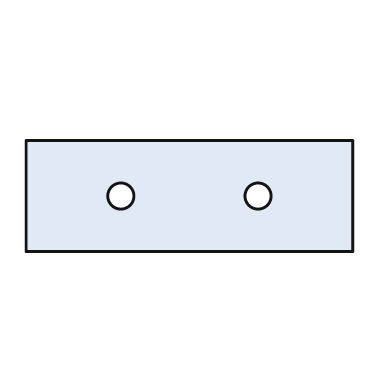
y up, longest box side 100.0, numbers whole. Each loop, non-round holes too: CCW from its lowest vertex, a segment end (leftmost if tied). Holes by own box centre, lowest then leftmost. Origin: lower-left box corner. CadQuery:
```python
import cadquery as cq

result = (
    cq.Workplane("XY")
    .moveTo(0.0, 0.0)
    .lineTo(100.0, 0.0)
    .lineTo(100.0, 34.0)
    .lineTo(0.0, 34.0)
    .close()
    .moveTo(29.0, 17.0)
    .circle(4.0)
    .moveTo(71.0, 17.0)
    .circle(4.0)
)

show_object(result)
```